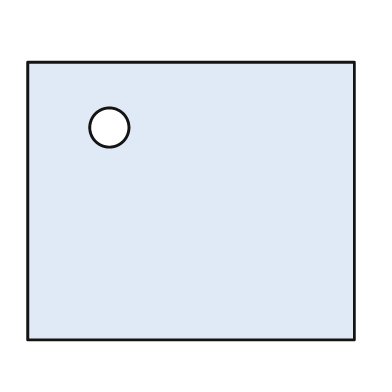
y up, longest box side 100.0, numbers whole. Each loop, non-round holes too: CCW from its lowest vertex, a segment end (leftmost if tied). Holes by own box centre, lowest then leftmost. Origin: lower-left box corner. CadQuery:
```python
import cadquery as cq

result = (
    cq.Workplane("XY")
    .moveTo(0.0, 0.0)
    .lineTo(100.0, 0.0)
    .lineTo(100.0, 85.0)
    .lineTo(0.0, 85.0)
    .close()
    .moveTo(25.0, 65.0)
    .circle(6.0)
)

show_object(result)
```